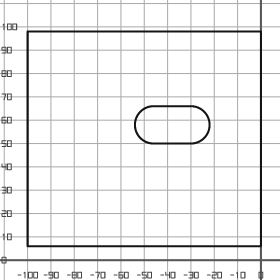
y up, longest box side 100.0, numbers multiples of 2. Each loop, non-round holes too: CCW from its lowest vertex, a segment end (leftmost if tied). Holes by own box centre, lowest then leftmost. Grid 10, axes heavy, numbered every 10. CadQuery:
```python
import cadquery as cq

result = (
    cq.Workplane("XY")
    .moveTo(-100.0, 6.0)
    .lineTo(0.0, 6.0)
    .lineTo(0.0, 98.0)
    .lineTo(-100.0, 98.0)
    .close()
    .moveTo(-46.0, 50.0)
    .lineTo(-30.0, 50.0)
    .threePointArc((-22.0, 58.0), (-30.0, 66.0))
    .lineTo(-46.0, 66.0)
    .threePointArc((-54.0, 58.0), (-46.0, 50.0))
    .close()
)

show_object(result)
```